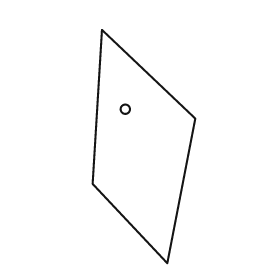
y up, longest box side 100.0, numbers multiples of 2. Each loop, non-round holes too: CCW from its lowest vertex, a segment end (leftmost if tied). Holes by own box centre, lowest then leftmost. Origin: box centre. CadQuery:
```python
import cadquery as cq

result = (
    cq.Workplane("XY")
    .moveTo(10.0, -50.0)
    .lineTo(22.0, 12.0)
    .lineTo(-18.0, 50.0)
    .lineTo(-22.0, -16.0)
    .close()
    .moveTo(-8.0, 16.0)
    .circle(2.0)
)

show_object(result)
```